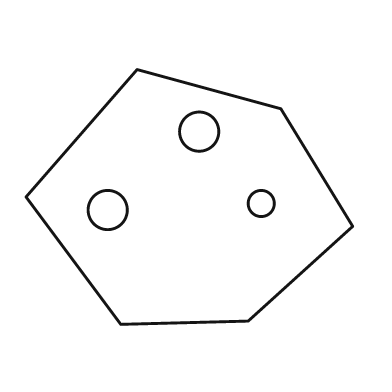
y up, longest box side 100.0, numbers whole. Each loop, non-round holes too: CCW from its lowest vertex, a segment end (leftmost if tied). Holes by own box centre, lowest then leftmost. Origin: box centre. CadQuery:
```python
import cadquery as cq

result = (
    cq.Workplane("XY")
    .moveTo(-21.0, -39.0)
    .lineTo(18.0, -38.0)
    .lineTo(50.0, -9.0)
    .lineTo(28.0, 27.0)
    .lineTo(-16.0, 39.0)
    .lineTo(-50.0, 0.0)
    .close()
    .moveTo(-25.0, -4.0)
    .circle(6.0)
    .moveTo(22.0, -2.0)
    .circle(4.0)
    .moveTo(3.0, 20.0)
    .circle(6.0)
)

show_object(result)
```